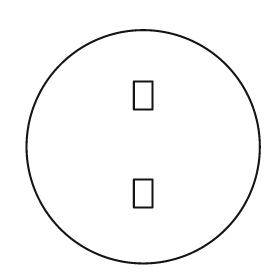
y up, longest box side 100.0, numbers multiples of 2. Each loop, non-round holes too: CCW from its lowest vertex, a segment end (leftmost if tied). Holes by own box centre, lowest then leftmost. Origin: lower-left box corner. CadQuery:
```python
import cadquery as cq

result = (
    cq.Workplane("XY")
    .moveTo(50.0, 50.0)
    .circle(50.0)
    .moveTo(46.0, 24.0)
    .lineTo(54.0, 24.0)
    .lineTo(54.0, 36.0)
    .lineTo(46.0, 36.0)
    .close()
    .moveTo(46.0, 66.0)
    .lineTo(54.0, 66.0)
    .lineTo(54.0, 78.0)
    .lineTo(46.0, 78.0)
    .close()
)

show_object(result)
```